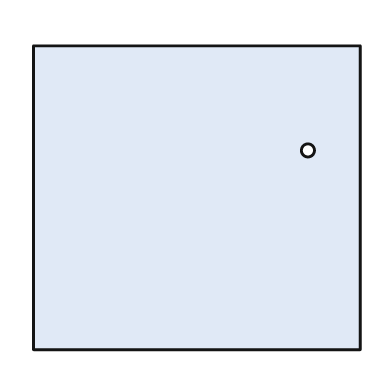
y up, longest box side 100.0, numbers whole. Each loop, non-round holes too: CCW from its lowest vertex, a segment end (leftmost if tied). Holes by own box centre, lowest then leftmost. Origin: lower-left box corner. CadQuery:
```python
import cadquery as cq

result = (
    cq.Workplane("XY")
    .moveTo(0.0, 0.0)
    .lineTo(100.0, 0.0)
    .lineTo(100.0, 93.0)
    .lineTo(0.0, 93.0)
    .close()
    .moveTo(84.0, 61.0)
    .circle(2.0)
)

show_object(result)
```